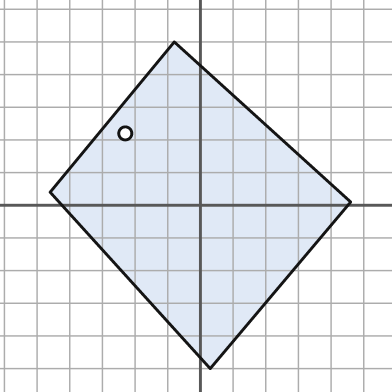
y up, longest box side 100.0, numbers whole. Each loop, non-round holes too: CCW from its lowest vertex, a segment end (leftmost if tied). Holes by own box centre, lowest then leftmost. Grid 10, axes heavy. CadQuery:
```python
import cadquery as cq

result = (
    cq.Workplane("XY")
    .moveTo(3.0, -50.0)
    .lineTo(46.0, 1.0)
    .lineTo(-8.0, 50.0)
    .lineTo(-46.0, 4.0)
    .close()
    .moveTo(-23.0, 22.0)
    .circle(2.0)
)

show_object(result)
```